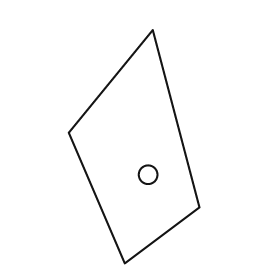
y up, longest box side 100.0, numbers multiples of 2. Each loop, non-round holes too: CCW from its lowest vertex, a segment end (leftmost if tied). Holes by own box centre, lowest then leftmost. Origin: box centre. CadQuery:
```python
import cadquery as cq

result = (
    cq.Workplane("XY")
    .moveTo(-4.0, -50.0)
    .lineTo(28.0, -26.0)
    .lineTo(8.0, 50.0)
    .lineTo(-28.0, 6.0)
    .close()
    .moveTo(6.0, -12.0)
    .circle(4.0)
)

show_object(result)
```